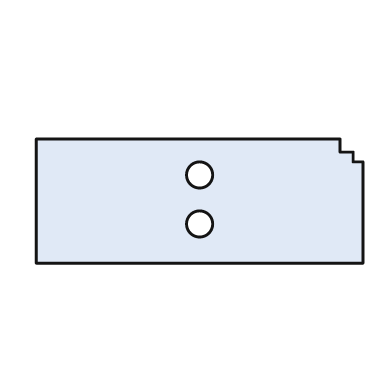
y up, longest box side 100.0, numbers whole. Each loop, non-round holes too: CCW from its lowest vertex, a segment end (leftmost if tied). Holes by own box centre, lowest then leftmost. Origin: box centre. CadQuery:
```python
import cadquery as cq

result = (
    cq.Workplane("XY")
    .moveTo(-50.0, -19.0)
    .lineTo(50.0, -19.0)
    .lineTo(50.0, 12.0)
    .lineTo(47.0, 12.0)
    .lineTo(47.0, 15.0)
    .lineTo(43.0, 15.0)
    .lineTo(43.0, 19.0)
    .lineTo(-50.0, 19.0)
    .close()
    .moveTo(0.0, -7.0)
    .circle(4.0)
    .moveTo(0.0, 8.0)
    .circle(4.0)
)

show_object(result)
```